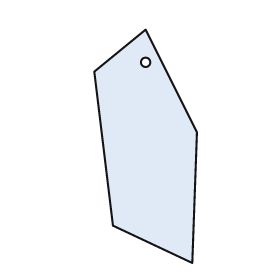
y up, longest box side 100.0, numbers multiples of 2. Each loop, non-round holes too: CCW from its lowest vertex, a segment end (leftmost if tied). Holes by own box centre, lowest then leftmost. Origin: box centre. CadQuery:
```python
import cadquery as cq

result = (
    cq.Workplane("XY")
    .moveTo(20.0, -50.0)
    .lineTo(22.0, 6.0)
    .lineTo(0.0, 50.0)
    .lineTo(-22.0, 32.0)
    .lineTo(-14.0, -34.0)
    .close()
    .moveTo(0.0, 36.0)
    .circle(2.0)
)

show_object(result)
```